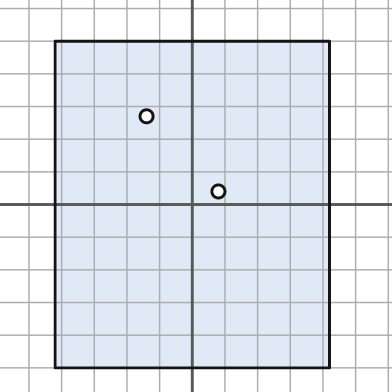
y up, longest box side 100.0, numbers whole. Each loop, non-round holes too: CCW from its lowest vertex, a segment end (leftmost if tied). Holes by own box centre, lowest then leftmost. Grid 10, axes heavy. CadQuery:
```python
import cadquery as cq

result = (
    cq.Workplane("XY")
    .moveTo(-42.0, -50.0)
    .lineTo(42.0, -50.0)
    .lineTo(42.0, 50.0)
    .lineTo(-42.0, 50.0)
    .close()
    .moveTo(8.0, 4.0)
    .circle(2.0)
    .moveTo(-14.0, 27.0)
    .circle(2.0)
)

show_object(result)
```